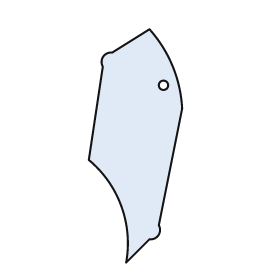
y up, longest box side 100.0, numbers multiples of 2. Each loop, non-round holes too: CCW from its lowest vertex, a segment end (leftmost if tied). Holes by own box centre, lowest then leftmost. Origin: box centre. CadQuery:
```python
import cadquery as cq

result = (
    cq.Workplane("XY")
    .moveTo(-4.0, -50.0)
    .lineTo(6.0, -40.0)
    .threePointArc((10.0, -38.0), (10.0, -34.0))
    .lineTo(20.0, 16.0)
    .threePointArc((16.0, 34.0), (6.0, 50.0))
    .lineTo(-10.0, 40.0)
    .threePointArc((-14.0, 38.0), (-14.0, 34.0))
    .lineTo(-20.0, -6.0)
    .threePointArc((-6.0, -26.0), (-4.0, -50.0))
    .close()
    .moveTo(12.0, 26.0)
    .circle(2.0)
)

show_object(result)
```